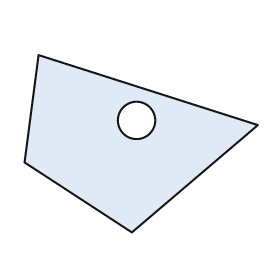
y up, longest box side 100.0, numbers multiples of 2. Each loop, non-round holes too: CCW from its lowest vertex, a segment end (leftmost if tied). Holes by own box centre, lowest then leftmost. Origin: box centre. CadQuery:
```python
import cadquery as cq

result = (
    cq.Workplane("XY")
    .moveTo(-4.0, -38.0)
    .lineTo(50.0, 8.0)
    .lineTo(-44.0, 38.0)
    .lineTo(-50.0, -8.0)
    .close()
    .moveTo(-2.0, 10.0)
    .circle(8.0)
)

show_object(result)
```